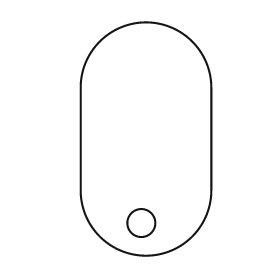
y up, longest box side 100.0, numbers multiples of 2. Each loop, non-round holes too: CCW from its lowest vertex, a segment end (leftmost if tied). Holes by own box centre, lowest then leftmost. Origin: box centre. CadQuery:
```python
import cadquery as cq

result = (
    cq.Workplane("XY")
    .moveTo(-28.0, -22.0)
    .threePointArc((0.0, -50.0), (28.0, -22.0))
    .lineTo(28.0, 22.0)
    .threePointArc((0.0, 50.0), (-28.0, 22.0))
    .close()
    .moveTo(-2.0, -36.0)
    .circle(6.0)
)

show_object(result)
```